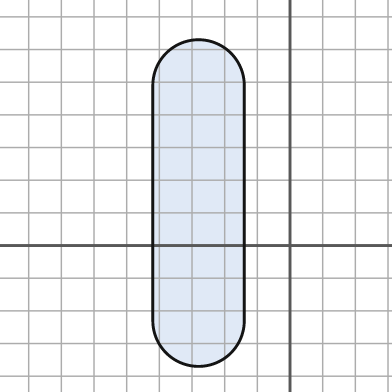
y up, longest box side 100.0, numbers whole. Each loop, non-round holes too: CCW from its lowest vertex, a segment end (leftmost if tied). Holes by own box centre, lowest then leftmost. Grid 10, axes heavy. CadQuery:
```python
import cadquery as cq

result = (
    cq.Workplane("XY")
    .moveTo(-42.0, -23.0)
    .threePointArc((-28.0, -37.0), (-14.0, -23.0))
    .lineTo(-14.0, 49.0)
    .threePointArc((-28.0, 63.0), (-42.0, 49.0))
    .close()
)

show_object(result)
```